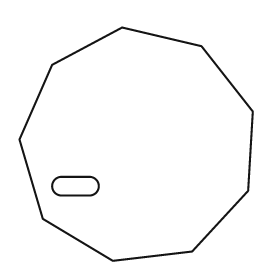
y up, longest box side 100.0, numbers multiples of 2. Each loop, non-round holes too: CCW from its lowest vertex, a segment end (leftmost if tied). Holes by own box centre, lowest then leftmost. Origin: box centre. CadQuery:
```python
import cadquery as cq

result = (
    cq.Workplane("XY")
    .moveTo(-10.0, -50.0)
    .lineTo(24.0, -46.0)
    .lineTo(48.0, -20.0)
    .lineTo(50.0, 14.0)
    .lineTo(28.0, 42.0)
    .lineTo(-6.0, 50.0)
    .lineTo(-36.0, 34.0)
    .lineTo(-50.0, 2.0)
    .lineTo(-40.0, -32.0)
    .close()
    .moveTo(-32.0, -22.0)
    .lineTo(-20.0, -22.0)
    .threePointArc((-16.0, -18.0), (-20.0, -14.0))
    .lineTo(-32.0, -14.0)
    .threePointArc((-36.0, -18.0), (-32.0, -22.0))
    .close()
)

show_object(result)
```